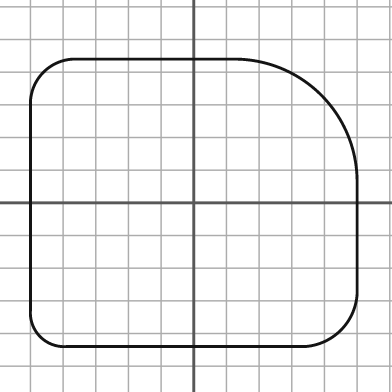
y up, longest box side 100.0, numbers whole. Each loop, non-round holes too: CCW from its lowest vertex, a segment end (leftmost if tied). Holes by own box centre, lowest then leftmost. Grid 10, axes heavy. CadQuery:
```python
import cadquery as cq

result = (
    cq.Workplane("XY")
    .moveTo(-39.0, -44.0)
    .lineTo(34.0, -44.0)
    .threePointArc((45.0, -39.0), (50.0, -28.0))
    .lineTo(50.0, 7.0)
    .threePointArc((39.0, 33.0), (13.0, 44.0))
    .lineTo(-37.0, 44.0)
    .threePointArc((-46.0, 40.0), (-50.0, 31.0))
    .lineTo(-50.0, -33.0)
    .threePointArc((-47.0, -41.0), (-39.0, -44.0))
    .close()
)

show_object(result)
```